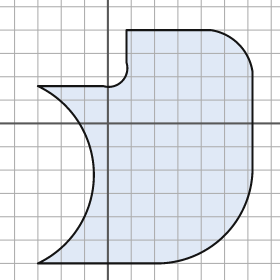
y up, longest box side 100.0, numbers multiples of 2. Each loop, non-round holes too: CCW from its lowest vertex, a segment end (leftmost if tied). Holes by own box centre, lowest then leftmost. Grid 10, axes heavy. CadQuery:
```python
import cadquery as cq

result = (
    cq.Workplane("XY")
    .moveTo(-30.0, -60.0)
    .lineTo(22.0, -60.0)
    .threePointArc((50.0, -48.0), (62.0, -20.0))
    .lineTo(62.0, 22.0)
    .threePointArc((56.0, 34.0), (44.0, 40.0))
    .lineTo(8.0, 40.0)
    .lineTo(8.0, 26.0)
    .threePointArc((6.0, 18.0), (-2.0, 16.0))
    .lineTo(-30.0, 16.0)
    .threePointArc((-6.0, -22.0), (-30.0, -60.0))
    .close()
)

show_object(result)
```